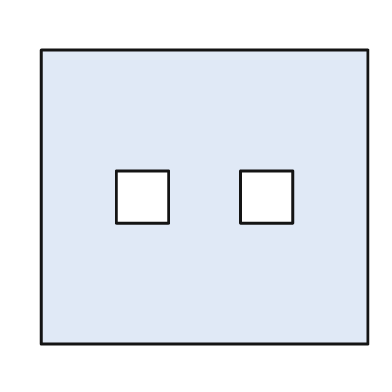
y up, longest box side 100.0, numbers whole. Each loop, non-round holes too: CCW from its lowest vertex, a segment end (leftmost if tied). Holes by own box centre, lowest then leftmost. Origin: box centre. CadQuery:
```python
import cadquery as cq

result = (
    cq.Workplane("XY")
    .moveTo(-50.0, -45.0)
    .lineTo(50.0, -45.0)
    .lineTo(50.0, 45.0)
    .lineTo(-50.0, 45.0)
    .close()
    .moveTo(-27.0, -8.0)
    .lineTo(-11.0, -8.0)
    .lineTo(-11.0, 8.0)
    .lineTo(-27.0, 8.0)
    .close()
    .moveTo(11.0, -8.0)
    .lineTo(27.0, -8.0)
    .lineTo(27.0, 8.0)
    .lineTo(11.0, 8.0)
    .close()
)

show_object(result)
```